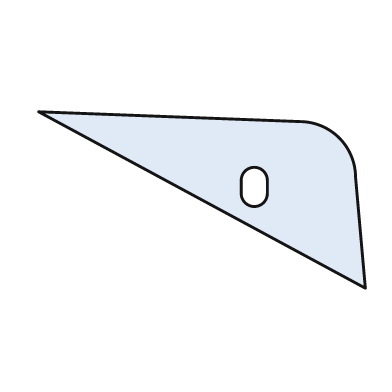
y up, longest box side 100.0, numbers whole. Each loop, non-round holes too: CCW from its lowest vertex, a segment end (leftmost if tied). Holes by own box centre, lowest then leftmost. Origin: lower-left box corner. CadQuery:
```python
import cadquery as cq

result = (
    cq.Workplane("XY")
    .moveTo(100.0, 0.0)
    .lineTo(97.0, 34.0)
    .threePointArc((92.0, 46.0), (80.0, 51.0))
    .lineTo(0.0, 54.0)
    .close()
    .moveTo(62.0, 29.0)
    .threePointArc((66.0, 25.0), (70.0, 29.0))
    .lineTo(70.0, 33.0)
    .threePointArc((66.0, 37.0), (62.0, 33.0))
    .close()
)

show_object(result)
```